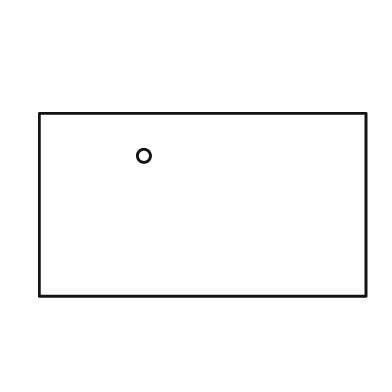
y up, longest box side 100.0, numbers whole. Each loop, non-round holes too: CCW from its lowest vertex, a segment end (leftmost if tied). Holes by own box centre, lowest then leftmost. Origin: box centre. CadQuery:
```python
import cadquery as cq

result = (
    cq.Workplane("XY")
    .moveTo(-50.0, -28.0)
    .lineTo(50.0, -28.0)
    .lineTo(50.0, 28.0)
    .lineTo(-50.0, 28.0)
    .close()
    .moveTo(-18.0, 15.0)
    .circle(2.0)
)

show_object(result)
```